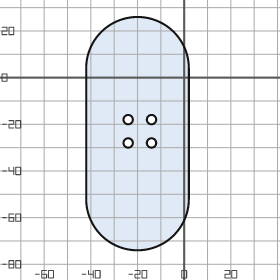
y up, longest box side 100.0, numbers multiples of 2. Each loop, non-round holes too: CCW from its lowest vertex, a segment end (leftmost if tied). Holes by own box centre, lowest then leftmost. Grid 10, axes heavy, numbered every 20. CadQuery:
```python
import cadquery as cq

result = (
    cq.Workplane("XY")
    .moveTo(-42.0, -52.0)
    .threePointArc((-20.0, -74.0), (2.0, -52.0))
    .lineTo(2.0, 4.0)
    .threePointArc((-20.0, 26.0), (-42.0, 4.0))
    .close()
    .moveTo(-24.0, -28.0)
    .circle(2.0)
    .moveTo(-14.0, -28.0)
    .circle(2.0)
    .moveTo(-24.0, -18.0)
    .circle(2.0)
    .moveTo(-14.0, -18.0)
    .circle(2.0)
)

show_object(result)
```